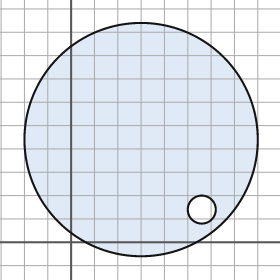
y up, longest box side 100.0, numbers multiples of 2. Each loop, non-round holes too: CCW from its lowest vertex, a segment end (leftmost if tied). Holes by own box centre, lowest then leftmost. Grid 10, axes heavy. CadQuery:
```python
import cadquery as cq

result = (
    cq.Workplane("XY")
    .moveTo(30.0, 44.0)
    .circle(50.0)
    .moveTo(56.0, 14.0)
    .circle(6.0)
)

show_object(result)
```